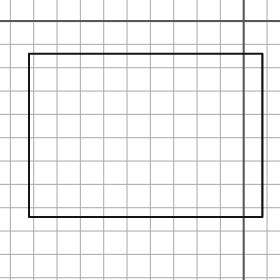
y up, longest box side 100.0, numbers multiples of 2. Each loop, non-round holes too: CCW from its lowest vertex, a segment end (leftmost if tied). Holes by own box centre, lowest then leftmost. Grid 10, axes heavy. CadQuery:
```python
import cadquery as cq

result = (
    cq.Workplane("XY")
    .moveTo(-92.0, -84.0)
    .lineTo(8.0, -84.0)
    .lineTo(8.0, -14.0)
    .lineTo(-92.0, -14.0)
    .close()
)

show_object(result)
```